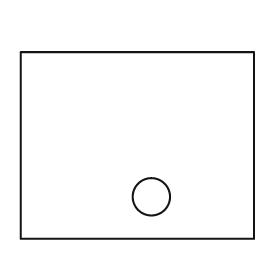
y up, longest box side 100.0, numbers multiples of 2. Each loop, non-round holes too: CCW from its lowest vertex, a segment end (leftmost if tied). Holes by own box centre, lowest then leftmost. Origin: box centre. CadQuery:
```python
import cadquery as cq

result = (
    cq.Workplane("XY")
    .moveTo(-50.0, -40.0)
    .lineTo(50.0, -40.0)
    .lineTo(50.0, 40.0)
    .lineTo(-50.0, 40.0)
    .close()
    .moveTo(6.0, -22.0)
    .circle(8.0)
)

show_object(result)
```